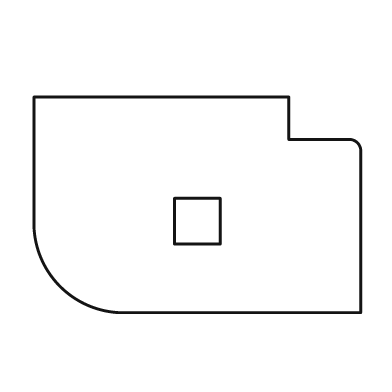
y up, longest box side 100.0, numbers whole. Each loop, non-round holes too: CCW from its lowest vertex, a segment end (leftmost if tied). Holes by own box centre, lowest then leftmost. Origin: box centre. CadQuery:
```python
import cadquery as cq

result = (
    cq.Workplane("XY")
    .moveTo(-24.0, -33.0)
    .lineTo(50.0, -33.0)
    .lineTo(50.0, 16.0)
    .threePointArc((49.0, 19.0), (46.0, 20.0))
    .lineTo(28.0, 20.0)
    .lineTo(28.0, 33.0)
    .lineTo(-50.0, 33.0)
    .lineTo(-50.0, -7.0)
    .threePointArc((-42.0, -25.0), (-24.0, -33.0))
    .close()
    .moveTo(-7.0, -12.0)
    .lineTo(7.0, -12.0)
    .lineTo(7.0, 2.0)
    .lineTo(-7.0, 2.0)
    .close()
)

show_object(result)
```